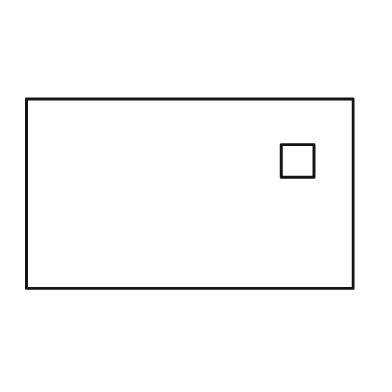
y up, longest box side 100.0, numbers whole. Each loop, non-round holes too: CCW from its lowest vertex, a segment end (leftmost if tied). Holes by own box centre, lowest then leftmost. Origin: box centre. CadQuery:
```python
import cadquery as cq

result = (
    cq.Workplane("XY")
    .moveTo(-50.0, -29.0)
    .lineTo(50.0, -29.0)
    .lineTo(50.0, 29.0)
    .lineTo(-50.0, 29.0)
    .close()
    .moveTo(28.0, 5.0)
    .lineTo(38.0, 5.0)
    .lineTo(38.0, 15.0)
    .lineTo(28.0, 15.0)
    .close()
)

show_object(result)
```